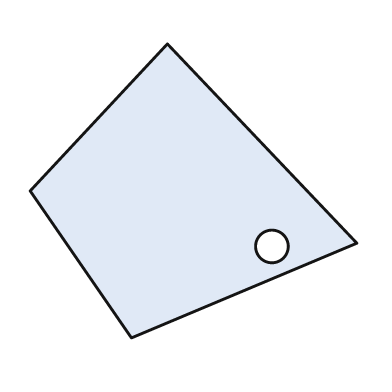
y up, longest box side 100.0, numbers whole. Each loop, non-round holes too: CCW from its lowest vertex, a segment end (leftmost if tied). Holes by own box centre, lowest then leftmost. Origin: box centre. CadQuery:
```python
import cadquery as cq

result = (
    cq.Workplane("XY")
    .moveTo(-19.0, -45.0)
    .lineTo(50.0, -16.0)
    .lineTo(-8.0, 45.0)
    .lineTo(-50.0, 0.0)
    .close()
    .moveTo(24.0, -17.0)
    .circle(5.0)
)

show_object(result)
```